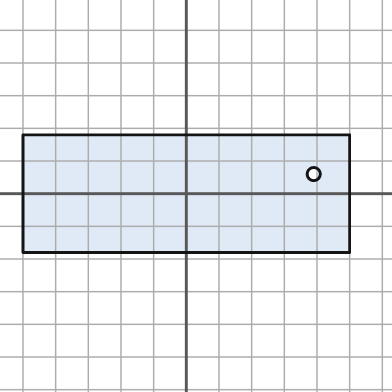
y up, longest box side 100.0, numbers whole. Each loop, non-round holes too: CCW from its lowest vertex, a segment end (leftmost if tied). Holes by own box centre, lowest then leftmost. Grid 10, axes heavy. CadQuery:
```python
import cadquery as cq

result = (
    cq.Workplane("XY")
    .moveTo(-50.0, -18.0)
    .lineTo(50.0, -18.0)
    .lineTo(50.0, 18.0)
    .lineTo(-50.0, 18.0)
    .close()
    .moveTo(39.0, 6.0)
    .circle(2.0)
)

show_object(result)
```